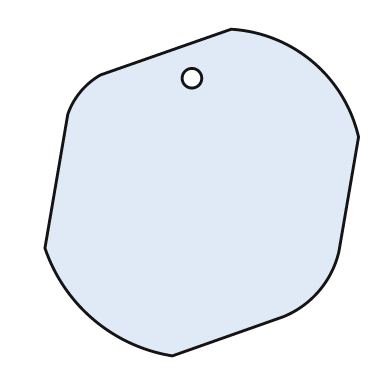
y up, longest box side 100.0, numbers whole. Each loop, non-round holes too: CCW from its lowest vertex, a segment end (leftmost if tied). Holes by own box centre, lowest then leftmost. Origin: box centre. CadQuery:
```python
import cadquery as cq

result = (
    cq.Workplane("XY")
    .moveTo(-9.0, -50.0)
    .lineTo(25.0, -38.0)
    .threePointArc((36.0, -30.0), (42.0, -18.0))
    .lineTo(48.0, 17.0)
    .threePointArc((34.0, 40.0), (9.0, 50.0))
    .lineTo(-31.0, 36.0)
    .threePointArc((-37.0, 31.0), (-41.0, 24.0))
    .lineTo(-48.0, -17.0)
    .threePointArc((-33.0, -39.0), (-9.0, -50.0))
    .close()
    .moveTo(-3.0, 35.0)
    .circle(3.0)
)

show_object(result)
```